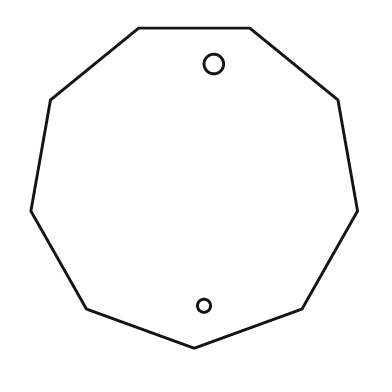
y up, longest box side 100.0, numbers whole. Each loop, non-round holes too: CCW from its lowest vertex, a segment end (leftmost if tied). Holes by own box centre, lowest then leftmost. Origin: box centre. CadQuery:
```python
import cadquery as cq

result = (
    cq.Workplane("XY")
    .moveTo(0.0, -49.0)
    .lineTo(33.0, -37.0)
    .lineTo(50.0, -7.0)
    .lineTo(44.0, 27.0)
    .lineTo(17.0, 49.0)
    .lineTo(-17.0, 49.0)
    .lineTo(-44.0, 27.0)
    .lineTo(-50.0, -7.0)
    .lineTo(-33.0, -37.0)
    .close()
    .moveTo(3.0, -36.0)
    .circle(2.0)
    .moveTo(6.0, 38.0)
    .circle(3.0)
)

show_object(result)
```